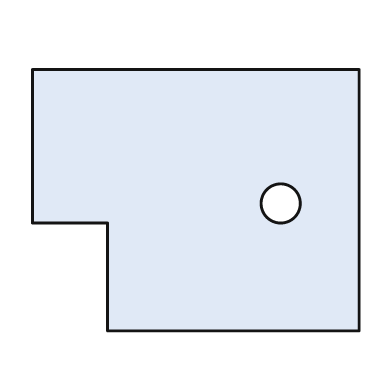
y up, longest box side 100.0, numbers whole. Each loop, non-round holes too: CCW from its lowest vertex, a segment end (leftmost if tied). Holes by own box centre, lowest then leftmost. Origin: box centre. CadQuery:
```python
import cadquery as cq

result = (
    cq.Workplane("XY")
    .moveTo(-27.0, -40.0)
    .lineTo(50.0, -40.0)
    .lineTo(50.0, 40.0)
    .lineTo(-50.0, 40.0)
    .lineTo(-50.0, -7.0)
    .lineTo(-27.0, -7.0)
    .close()
    .moveTo(26.0, -1.0)
    .circle(6.0)
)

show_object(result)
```